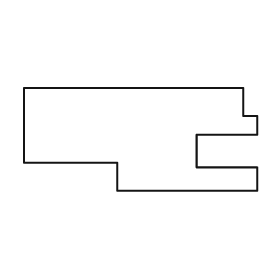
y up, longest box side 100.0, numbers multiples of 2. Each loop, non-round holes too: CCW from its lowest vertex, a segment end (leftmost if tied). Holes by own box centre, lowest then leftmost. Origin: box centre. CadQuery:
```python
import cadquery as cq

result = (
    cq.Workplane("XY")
    .moveTo(-10.0, -22.0)
    .lineTo(50.0, -22.0)
    .lineTo(50.0, -12.0)
    .lineTo(24.0, -12.0)
    .lineTo(24.0, 2.0)
    .lineTo(50.0, 2.0)
    .lineTo(50.0, 10.0)
    .lineTo(44.0, 10.0)
    .lineTo(44.0, 22.0)
    .lineTo(-50.0, 22.0)
    .lineTo(-50.0, -10.0)
    .lineTo(-10.0, -10.0)
    .close()
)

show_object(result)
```